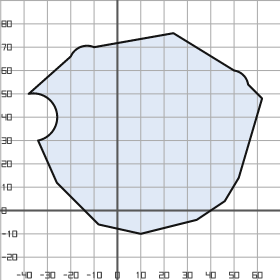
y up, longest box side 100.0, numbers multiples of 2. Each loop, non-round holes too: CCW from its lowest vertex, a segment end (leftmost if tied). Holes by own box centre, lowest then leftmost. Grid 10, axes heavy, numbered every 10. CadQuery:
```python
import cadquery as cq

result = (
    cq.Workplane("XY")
    .moveTo(10.0, -10.0)
    .lineTo(34.0, -4.0)
    .lineTo(46.0, 4.0)
    .lineTo(52.0, 14.0)
    .lineTo(62.0, 48.0)
    .lineTo(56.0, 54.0)
    .threePointArc((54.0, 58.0), (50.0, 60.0))
    .lineTo(24.0, 76.0)
    .lineTo(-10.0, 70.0)
    .threePointArc((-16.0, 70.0), (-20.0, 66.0))
    .lineTo(-38.0, 50.0)
    .threePointArc((-26.0, 42.0), (-34.0, 30.0))
    .lineTo(-26.0, 12.0)
    .lineTo(-8.0, -6.0)
    .close()
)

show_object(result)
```